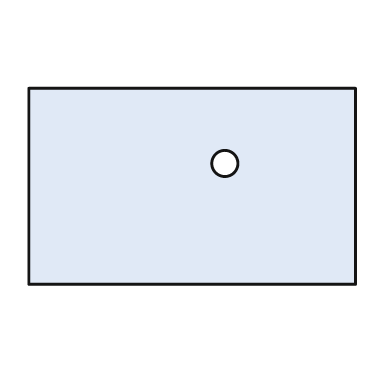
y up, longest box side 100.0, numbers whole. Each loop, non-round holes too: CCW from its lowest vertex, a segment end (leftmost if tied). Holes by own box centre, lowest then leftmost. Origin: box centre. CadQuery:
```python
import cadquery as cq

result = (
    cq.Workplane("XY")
    .moveTo(-50.0, -30.0)
    .lineTo(50.0, -30.0)
    .lineTo(50.0, 30.0)
    .lineTo(-50.0, 30.0)
    .close()
    .moveTo(10.0, 7.0)
    .circle(4.0)
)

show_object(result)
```